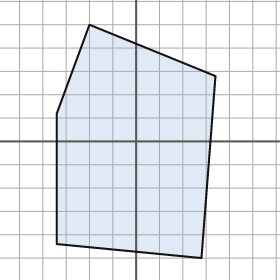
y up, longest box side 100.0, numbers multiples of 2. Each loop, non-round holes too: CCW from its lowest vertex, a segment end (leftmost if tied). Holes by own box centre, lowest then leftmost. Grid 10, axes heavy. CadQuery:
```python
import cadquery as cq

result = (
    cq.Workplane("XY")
    .moveTo(28.0, -50.0)
    .lineTo(34.0, 28.0)
    .lineTo(-20.0, 50.0)
    .lineTo(-34.0, 12.0)
    .lineTo(-34.0, -44.0)
    .close()
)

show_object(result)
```